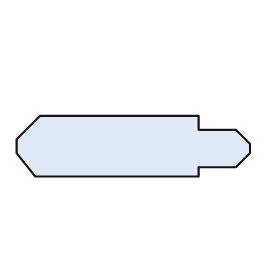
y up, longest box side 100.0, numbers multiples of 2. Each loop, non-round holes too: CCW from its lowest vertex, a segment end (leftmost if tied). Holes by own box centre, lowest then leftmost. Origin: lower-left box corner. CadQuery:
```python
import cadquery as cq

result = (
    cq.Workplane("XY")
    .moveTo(8.0, 0.0)
    .lineTo(78.0, 0.0)
    .lineTo(78.0, 4.0)
    .lineTo(94.0, 4.0)
    .lineTo(100.0, 10.0)
    .lineTo(100.0, 14.0)
    .lineTo(94.0, 20.0)
    .lineTo(78.0, 20.0)
    .lineTo(78.0, 26.0)
    .lineTo(10.0, 26.0)
    .lineTo(0.0, 16.0)
    .lineTo(0.0, 10.0)
    .close()
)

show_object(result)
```